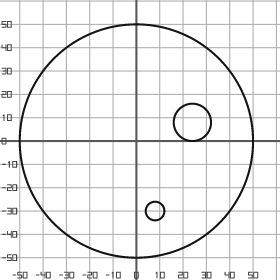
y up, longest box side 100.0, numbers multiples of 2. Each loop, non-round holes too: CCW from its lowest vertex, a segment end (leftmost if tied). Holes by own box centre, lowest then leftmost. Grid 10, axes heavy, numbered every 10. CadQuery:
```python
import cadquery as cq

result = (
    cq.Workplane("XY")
    .moveTo(0.0, 0.0)
    .circle(50.0)
    .moveTo(8.0, -30.0)
    .circle(4.0)
    .moveTo(24.0, 8.0)
    .circle(8.0)
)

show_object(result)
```